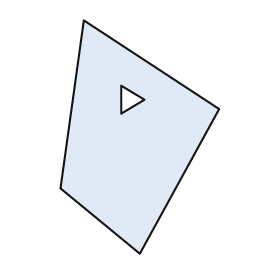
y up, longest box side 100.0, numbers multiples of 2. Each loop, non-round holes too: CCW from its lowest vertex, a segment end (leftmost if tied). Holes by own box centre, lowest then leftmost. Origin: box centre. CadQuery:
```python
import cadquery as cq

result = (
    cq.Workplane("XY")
    .moveTo(0.0, -50.0)
    .lineTo(34.0, 12.0)
    .lineTo(-24.0, 50.0)
    .lineTo(-34.0, -22.0)
    .close()
    .moveTo(-8.0, 10.0)
    .lineTo(2.0, 16.0)
    .lineTo(-8.0, 22.0)
    .close()
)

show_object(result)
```